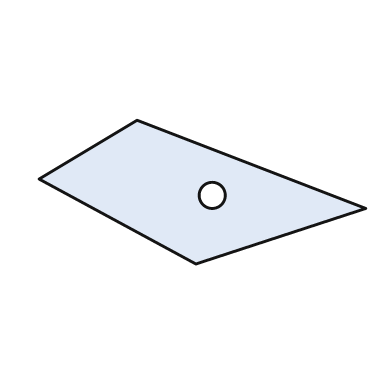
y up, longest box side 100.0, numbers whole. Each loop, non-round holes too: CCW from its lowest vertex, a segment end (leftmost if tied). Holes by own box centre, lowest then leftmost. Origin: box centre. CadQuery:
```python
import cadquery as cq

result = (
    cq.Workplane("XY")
    .moveTo(-2.0, -22.0)
    .lineTo(50.0, -5.0)
    .lineTo(-20.0, 22.0)
    .lineTo(-50.0, 4.0)
    .close()
    .moveTo(3.0, -1.0)
    .circle(4.0)
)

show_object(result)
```